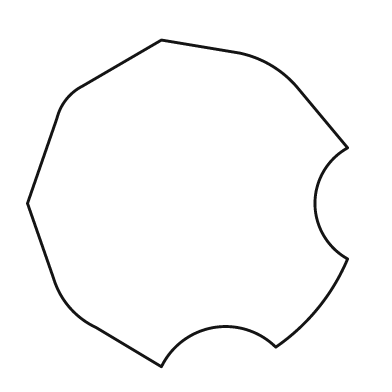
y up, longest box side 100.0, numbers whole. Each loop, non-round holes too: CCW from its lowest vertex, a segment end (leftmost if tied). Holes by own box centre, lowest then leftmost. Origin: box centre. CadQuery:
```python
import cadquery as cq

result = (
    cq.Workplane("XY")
    .moveTo(-8.0, -50.0)
    .threePointArc((8.0, -38.0), (27.0, -44.0))
    .threePointArc((40.0, -32.0), (49.0, -17.0))
    .threePointArc((39.0, 0.0), (49.0, 17.0))
    .lineTo(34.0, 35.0)
    .threePointArc((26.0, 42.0), (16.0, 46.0))
    .lineTo(-8.0, 50.0)
    .lineTo(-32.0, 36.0)
    .threePointArc((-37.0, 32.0), (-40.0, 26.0))
    .lineTo(-49.0, 0.0)
    .lineTo(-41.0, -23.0)
    .threePointArc((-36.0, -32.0), (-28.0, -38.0))
    .close()
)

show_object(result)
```